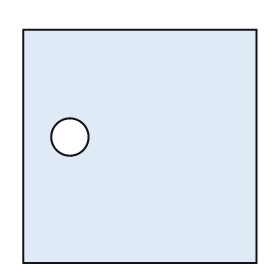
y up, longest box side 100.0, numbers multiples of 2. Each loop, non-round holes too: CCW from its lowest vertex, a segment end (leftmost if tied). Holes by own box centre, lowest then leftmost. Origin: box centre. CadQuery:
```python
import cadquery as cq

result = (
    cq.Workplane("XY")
    .moveTo(-50.0, -50.0)
    .lineTo(50.0, -50.0)
    .lineTo(50.0, 50.0)
    .lineTo(-50.0, 50.0)
    .close()
    .moveTo(-30.0, 4.0)
    .circle(8.0)
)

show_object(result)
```